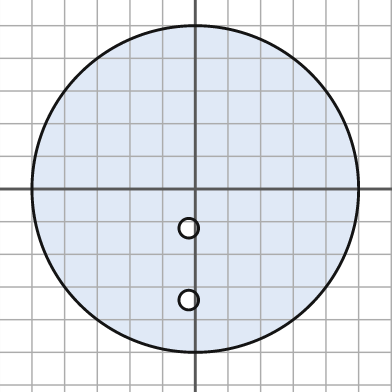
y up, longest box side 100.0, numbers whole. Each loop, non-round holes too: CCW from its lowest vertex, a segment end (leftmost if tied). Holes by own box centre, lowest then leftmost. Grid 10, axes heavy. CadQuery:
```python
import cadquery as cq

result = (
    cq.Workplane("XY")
    .moveTo(0.0, 0.0)
    .circle(50.0)
    .moveTo(-2.0, -34.0)
    .circle(3.0)
    .moveTo(-2.0, -12.0)
    .circle(3.0)
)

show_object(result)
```